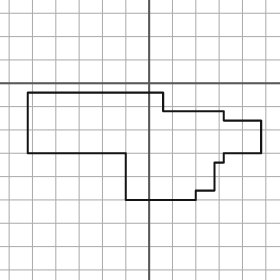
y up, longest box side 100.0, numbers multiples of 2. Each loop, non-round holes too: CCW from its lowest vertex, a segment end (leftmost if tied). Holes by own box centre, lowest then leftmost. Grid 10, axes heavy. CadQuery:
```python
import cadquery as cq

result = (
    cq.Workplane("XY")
    .moveTo(-10.0, -50.0)
    .lineTo(20.0, -50.0)
    .lineTo(20.0, -46.0)
    .lineTo(28.0, -46.0)
    .lineTo(28.0, -34.0)
    .lineTo(32.0, -34.0)
    .lineTo(32.0, -30.0)
    .lineTo(48.0, -30.0)
    .lineTo(48.0, -16.0)
    .lineTo(32.0, -16.0)
    .lineTo(32.0, -12.0)
    .lineTo(6.0, -12.0)
    .lineTo(6.0, -4.0)
    .lineTo(-52.0, -4.0)
    .lineTo(-52.0, -30.0)
    .lineTo(-10.0, -30.0)
    .close()
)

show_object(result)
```